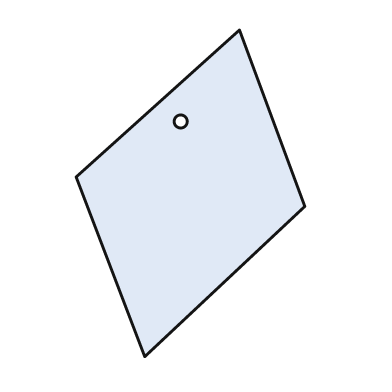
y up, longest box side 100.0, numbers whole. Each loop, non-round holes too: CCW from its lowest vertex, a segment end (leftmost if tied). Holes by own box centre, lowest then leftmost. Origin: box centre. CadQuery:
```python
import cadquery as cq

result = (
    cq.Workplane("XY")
    .moveTo(-14.0, -50.0)
    .lineTo(35.0, -4.0)
    .lineTo(15.0, 50.0)
    .lineTo(-35.0, 5.0)
    .close()
    .moveTo(-3.0, 22.0)
    .circle(2.0)
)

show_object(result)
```